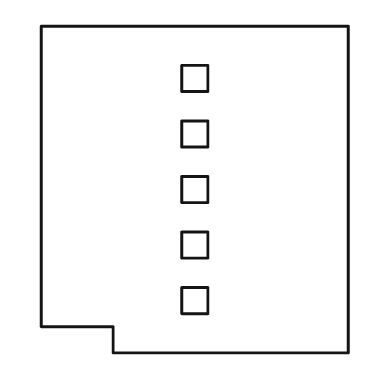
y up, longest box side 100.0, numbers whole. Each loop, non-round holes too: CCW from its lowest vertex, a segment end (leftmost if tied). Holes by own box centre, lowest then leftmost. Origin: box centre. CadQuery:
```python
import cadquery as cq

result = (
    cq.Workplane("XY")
    .moveTo(-25.0, -50.0)
    .lineTo(47.0, -50.0)
    .lineTo(47.0, 50.0)
    .lineTo(-47.0, 50.0)
    .lineTo(-47.0, -42.0)
    .lineTo(-25.0, -42.0)
    .close()
    .moveTo(-4.0, -38.0)
    .lineTo(4.0, -38.0)
    .lineTo(4.0, -30.0)
    .lineTo(-4.0, -30.0)
    .close()
    .moveTo(-4.0, -21.0)
    .lineTo(4.0, -21.0)
    .lineTo(4.0, -13.0)
    .lineTo(-4.0, -13.0)
    .close()
    .moveTo(-4.0, -4.0)
    .lineTo(4.0, -4.0)
    .lineTo(4.0, 4.0)
    .lineTo(-4.0, 4.0)
    .close()
    .moveTo(-4.0, 13.0)
    .lineTo(4.0, 13.0)
    .lineTo(4.0, 21.0)
    .lineTo(-4.0, 21.0)
    .close()
    .moveTo(-4.0, 30.0)
    .lineTo(4.0, 30.0)
    .lineTo(4.0, 38.0)
    .lineTo(-4.0, 38.0)
    .close()
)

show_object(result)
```